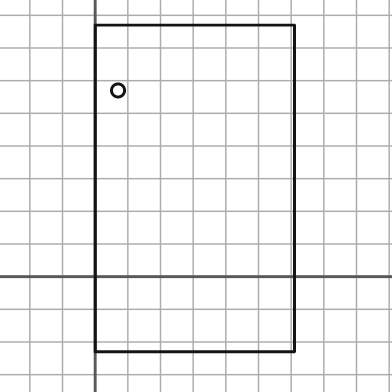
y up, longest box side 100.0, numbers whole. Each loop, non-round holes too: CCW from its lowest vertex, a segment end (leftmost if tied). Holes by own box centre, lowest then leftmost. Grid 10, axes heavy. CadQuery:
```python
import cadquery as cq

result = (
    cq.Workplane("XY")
    .moveTo(0.0, -23.0)
    .lineTo(61.0, -23.0)
    .lineTo(61.0, 77.0)
    .lineTo(0.0, 77.0)
    .close()
    .moveTo(7.0, 57.0)
    .circle(2.0)
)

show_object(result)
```